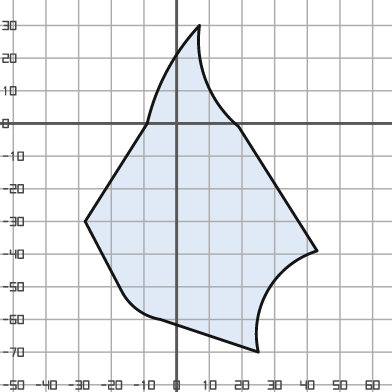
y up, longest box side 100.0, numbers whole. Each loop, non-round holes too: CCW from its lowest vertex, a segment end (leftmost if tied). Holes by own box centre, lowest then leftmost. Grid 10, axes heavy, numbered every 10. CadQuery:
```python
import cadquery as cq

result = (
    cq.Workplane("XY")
    .moveTo(25.0, -70.0)
    .threePointArc((28.0, -51.0), (43.0, -39.0))
    .lineTo(19.0, -1.0)
    .threePointArc((9.0, 13.0), (7.0, 30.0))
    .threePointArc((-3.0, 16.0), (-9.0, 0.0))
    .lineTo(-28.0, -30.0)
    .lineTo(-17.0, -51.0)
    .threePointArc((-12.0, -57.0), (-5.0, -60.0))
    .close()
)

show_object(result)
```